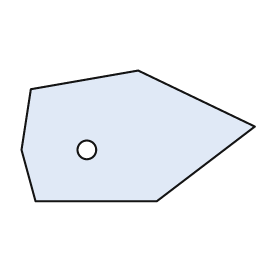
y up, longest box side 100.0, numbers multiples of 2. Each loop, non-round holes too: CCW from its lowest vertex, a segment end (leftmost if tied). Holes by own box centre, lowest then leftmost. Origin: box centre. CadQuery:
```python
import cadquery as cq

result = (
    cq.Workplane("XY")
    .moveTo(-44.0, -28.0)
    .lineTo(8.0, -28.0)
    .lineTo(50.0, 4.0)
    .lineTo(0.0, 28.0)
    .lineTo(-46.0, 20.0)
    .lineTo(-50.0, -6.0)
    .close()
    .moveTo(-22.0, -6.0)
    .circle(4.0)
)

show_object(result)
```